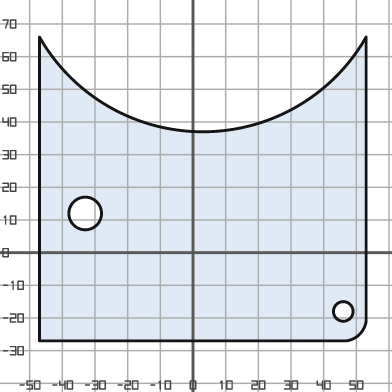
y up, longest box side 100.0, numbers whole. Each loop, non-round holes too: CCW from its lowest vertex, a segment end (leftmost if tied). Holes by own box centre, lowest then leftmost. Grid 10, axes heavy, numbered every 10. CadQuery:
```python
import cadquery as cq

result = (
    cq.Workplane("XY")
    .moveTo(-47.0, -27.0)
    .lineTo(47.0, -27.0)
    .threePointArc((51.0, -25.0), (53.0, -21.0))
    .lineTo(53.0, 66.0)
    .threePointArc((3.0, 37.0), (-47.0, 66.0))
    .close()
    .moveTo(46.0, -18.0)
    .circle(3.0)
    .moveTo(-33.0, 12.0)
    .circle(5.0)
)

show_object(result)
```